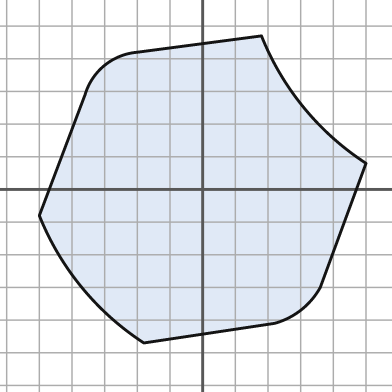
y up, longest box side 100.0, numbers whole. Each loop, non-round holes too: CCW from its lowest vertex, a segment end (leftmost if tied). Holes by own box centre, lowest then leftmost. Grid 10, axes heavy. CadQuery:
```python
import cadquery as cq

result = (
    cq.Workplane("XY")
    .moveTo(-18.0, -47.0)
    .lineTo(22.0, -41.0)
    .threePointArc((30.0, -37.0), (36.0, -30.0))
    .lineTo(50.0, 8.0)
    .threePointArc((31.0, 25.0), (18.0, 47.0))
    .lineTo(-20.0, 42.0)
    .threePointArc((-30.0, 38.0), (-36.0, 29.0))
    .lineTo(-50.0, -8.0)
    .threePointArc((-37.0, -30.0), (-18.0, -47.0))
    .close()
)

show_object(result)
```